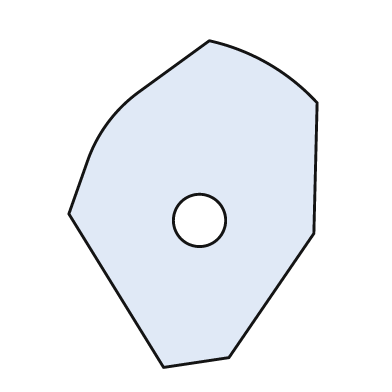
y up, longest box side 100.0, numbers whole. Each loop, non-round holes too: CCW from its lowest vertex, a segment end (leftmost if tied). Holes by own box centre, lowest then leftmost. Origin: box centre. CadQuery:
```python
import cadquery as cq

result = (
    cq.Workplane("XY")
    .moveTo(-9.0, -50.0)
    .lineTo(11.0, -47.0)
    .lineTo(37.0, -9.0)
    .lineTo(38.0, 31.0)
    .threePointArc((23.0, 43.0), (5.0, 50.0))
    .lineTo(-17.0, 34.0)
    .threePointArc((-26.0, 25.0), (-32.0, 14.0))
    .lineTo(-38.0, -3.0)
    .close()
    .moveTo(2.0, -5.0)
    .circle(8.0)
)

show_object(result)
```